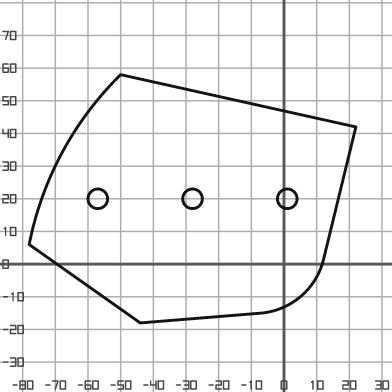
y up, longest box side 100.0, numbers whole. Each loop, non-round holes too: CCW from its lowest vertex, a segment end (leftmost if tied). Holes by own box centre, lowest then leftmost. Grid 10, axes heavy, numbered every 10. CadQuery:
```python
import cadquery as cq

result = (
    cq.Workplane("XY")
    .moveTo(-44.0, -18.0)
    .lineTo(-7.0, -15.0)
    .threePointArc((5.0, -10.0), (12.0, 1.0))
    .lineTo(22.0, 42.0)
    .lineTo(-50.0, 58.0)
    .threePointArc((-68.0, 34.0), (-78.0, 6.0))
    .close()
    .moveTo(-57.0, 20.0)
    .circle(3.0)
    .moveTo(-28.0, 20.0)
    .circle(3.0)
    .moveTo(1.0, 20.0)
    .circle(3.0)
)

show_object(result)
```